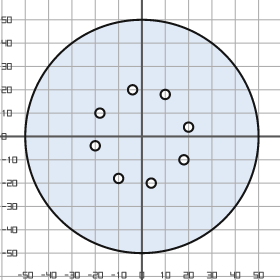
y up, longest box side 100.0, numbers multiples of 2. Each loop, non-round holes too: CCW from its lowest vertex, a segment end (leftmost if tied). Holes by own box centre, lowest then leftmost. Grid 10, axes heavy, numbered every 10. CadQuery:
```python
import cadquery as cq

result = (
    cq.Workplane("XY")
    .moveTo(0.0, 0.0)
    .circle(50.0)
    .moveTo(4.0, -20.0)
    .circle(2.0)
    .moveTo(-10.0, -18.0)
    .circle(2.0)
    .moveTo(18.0, -10.0)
    .circle(2.0)
    .moveTo(-20.0, -4.0)
    .circle(2.0)
    .moveTo(20.0, 4.0)
    .circle(2.0)
    .moveTo(-18.0, 10.0)
    .circle(2.0)
    .moveTo(10.0, 18.0)
    .circle(2.0)
    .moveTo(-4.0, 20.0)
    .circle(2.0)
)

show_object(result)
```